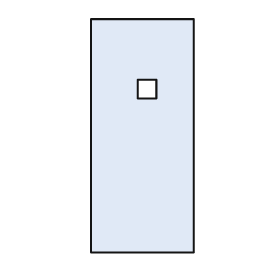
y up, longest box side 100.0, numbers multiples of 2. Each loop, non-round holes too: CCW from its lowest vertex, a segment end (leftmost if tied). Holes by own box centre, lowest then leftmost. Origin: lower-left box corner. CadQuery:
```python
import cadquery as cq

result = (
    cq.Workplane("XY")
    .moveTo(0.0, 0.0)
    .lineTo(44.0, 0.0)
    .lineTo(44.0, 100.0)
    .lineTo(0.0, 100.0)
    .close()
    .moveTo(20.0, 66.0)
    .lineTo(28.0, 66.0)
    .lineTo(28.0, 74.0)
    .lineTo(20.0, 74.0)
    .close()
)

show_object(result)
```